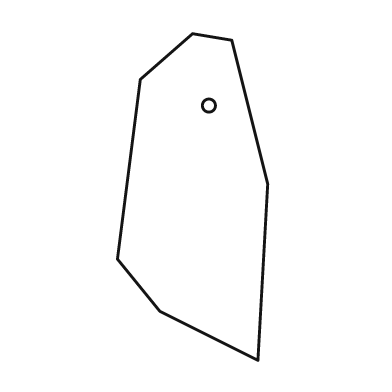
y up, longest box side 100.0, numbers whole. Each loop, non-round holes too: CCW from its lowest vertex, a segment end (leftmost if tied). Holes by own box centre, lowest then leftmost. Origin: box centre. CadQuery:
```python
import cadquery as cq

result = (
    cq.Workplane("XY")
    .moveTo(20.0, -50.0)
    .lineTo(23.0, 4.0)
    .lineTo(12.0, 48.0)
    .lineTo(0.0, 50.0)
    .lineTo(-16.0, 36.0)
    .lineTo(-23.0, -19.0)
    .lineTo(-10.0, -35.0)
    .close()
    .moveTo(5.0, 28.0)
    .circle(2.0)
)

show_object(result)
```